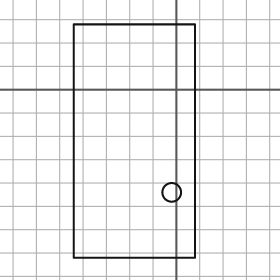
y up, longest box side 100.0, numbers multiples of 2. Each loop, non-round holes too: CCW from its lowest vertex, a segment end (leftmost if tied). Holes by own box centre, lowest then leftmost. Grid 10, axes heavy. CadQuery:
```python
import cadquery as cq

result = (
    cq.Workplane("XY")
    .moveTo(-44.0, -72.0)
    .lineTo(8.0, -72.0)
    .lineTo(8.0, 28.0)
    .lineTo(-44.0, 28.0)
    .close()
    .moveTo(-2.0, -44.0)
    .circle(4.0)
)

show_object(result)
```